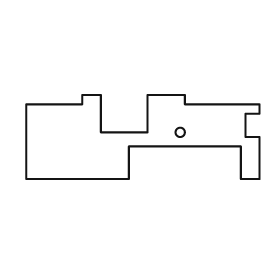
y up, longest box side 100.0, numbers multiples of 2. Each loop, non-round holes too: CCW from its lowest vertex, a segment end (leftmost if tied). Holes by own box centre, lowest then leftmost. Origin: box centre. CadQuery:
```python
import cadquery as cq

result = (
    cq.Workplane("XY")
    .moveTo(-50.0, -18.0)
    .lineTo(-6.0, -18.0)
    .lineTo(-6.0, -4.0)
    .lineTo(42.0, -4.0)
    .lineTo(42.0, -18.0)
    .lineTo(50.0, -18.0)
    .lineTo(50.0, 0.0)
    .lineTo(44.0, 0.0)
    .lineTo(44.0, 10.0)
    .lineTo(50.0, 10.0)
    .lineTo(50.0, 14.0)
    .lineTo(18.0, 14.0)
    .lineTo(18.0, 18.0)
    .lineTo(2.0, 18.0)
    .lineTo(2.0, 2.0)
    .lineTo(-18.0, 2.0)
    .lineTo(-18.0, 18.0)
    .lineTo(-26.0, 18.0)
    .lineTo(-26.0, 14.0)
    .lineTo(-50.0, 14.0)
    .close()
    .moveTo(16.0, 2.0)
    .circle(2.0)
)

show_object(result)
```